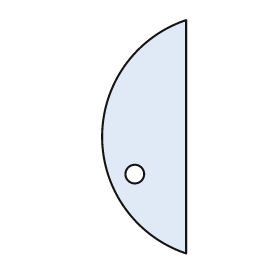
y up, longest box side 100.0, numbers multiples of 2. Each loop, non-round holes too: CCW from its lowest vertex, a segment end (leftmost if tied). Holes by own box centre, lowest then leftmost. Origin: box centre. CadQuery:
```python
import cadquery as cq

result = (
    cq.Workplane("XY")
    .moveTo(18.0, -50.0)
    .lineTo(18.0, 50.0)
    .threePointArc((-18.0, 0.0), (18.0, -50.0))
    .close()
    .moveTo(-4.0, -16.0)
    .circle(4.0)
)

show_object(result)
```